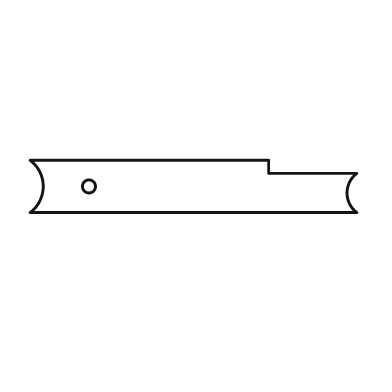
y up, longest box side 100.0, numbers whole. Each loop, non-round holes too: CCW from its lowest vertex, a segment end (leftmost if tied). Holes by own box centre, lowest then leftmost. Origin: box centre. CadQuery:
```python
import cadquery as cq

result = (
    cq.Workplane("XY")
    .moveTo(-50.0, -8.0)
    .lineTo(50.0, -8.0)
    .threePointArc((47.0, -2.0), (50.0, 4.0))
    .lineTo(23.0, 4.0)
    .lineTo(23.0, 8.0)
    .lineTo(-50.0, 8.0)
    .threePointArc((-46.0, 0.0), (-50.0, -8.0))
    .close()
    .moveTo(-32.0, 0.0)
    .circle(2.0)
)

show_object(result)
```